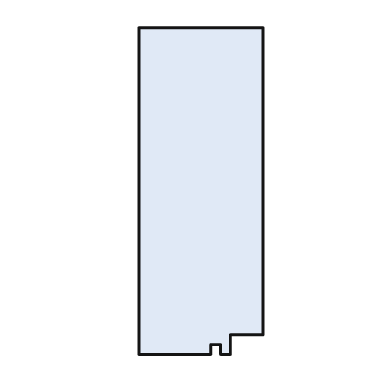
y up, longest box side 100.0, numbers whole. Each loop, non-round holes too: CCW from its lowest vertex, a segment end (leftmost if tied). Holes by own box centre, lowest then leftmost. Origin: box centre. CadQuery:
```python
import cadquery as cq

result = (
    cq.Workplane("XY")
    .moveTo(-19.0, -50.0)
    .lineTo(3.0, -50.0)
    .lineTo(3.0, -47.0)
    .lineTo(6.0, -47.0)
    .lineTo(6.0, -50.0)
    .lineTo(9.0, -50.0)
    .lineTo(9.0, -44.0)
    .lineTo(19.0, -44.0)
    .lineTo(19.0, 50.0)
    .lineTo(-19.0, 50.0)
    .close()
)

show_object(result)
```